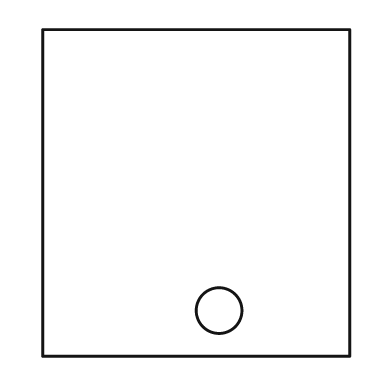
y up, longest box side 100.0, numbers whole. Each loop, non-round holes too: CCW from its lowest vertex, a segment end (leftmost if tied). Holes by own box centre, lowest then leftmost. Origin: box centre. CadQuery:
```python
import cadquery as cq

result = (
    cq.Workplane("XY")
    .moveTo(-47.0, -50.0)
    .lineTo(47.0, -50.0)
    .lineTo(47.0, 50.0)
    .lineTo(-47.0, 50.0)
    .close()
    .moveTo(7.0, -36.0)
    .circle(7.0)
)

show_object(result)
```